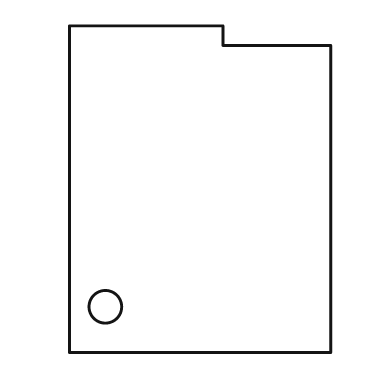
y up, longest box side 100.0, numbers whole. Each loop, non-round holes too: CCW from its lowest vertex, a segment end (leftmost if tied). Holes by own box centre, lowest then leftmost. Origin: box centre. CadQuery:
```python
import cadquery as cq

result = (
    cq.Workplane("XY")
    .moveTo(-40.0, -50.0)
    .lineTo(40.0, -50.0)
    .lineTo(40.0, 44.0)
    .lineTo(7.0, 44.0)
    .lineTo(7.0, 50.0)
    .lineTo(-40.0, 50.0)
    .close()
    .moveTo(-29.0, -36.0)
    .circle(5.0)
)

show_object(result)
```